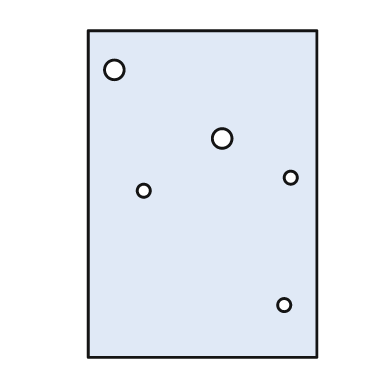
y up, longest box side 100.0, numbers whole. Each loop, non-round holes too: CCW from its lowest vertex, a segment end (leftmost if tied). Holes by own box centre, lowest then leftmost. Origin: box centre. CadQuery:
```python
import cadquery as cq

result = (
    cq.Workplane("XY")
    .moveTo(-35.0, -50.0)
    .lineTo(35.0, -50.0)
    .lineTo(35.0, 50.0)
    .lineTo(-35.0, 50.0)
    .close()
    .moveTo(25.0, -34.0)
    .circle(2.0)
    .moveTo(-18.0, 1.0)
    .circle(2.0)
    .moveTo(27.0, 5.0)
    .circle(2.0)
    .moveTo(6.0, 17.0)
    .circle(3.0)
    .moveTo(-27.0, 38.0)
    .circle(3.0)
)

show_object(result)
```